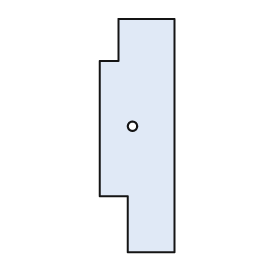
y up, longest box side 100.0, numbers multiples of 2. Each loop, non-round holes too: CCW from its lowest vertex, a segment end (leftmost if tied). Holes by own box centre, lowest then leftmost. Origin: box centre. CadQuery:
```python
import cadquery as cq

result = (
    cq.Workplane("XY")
    .moveTo(-4.0, -50.0)
    .lineTo(16.0, -50.0)
    .lineTo(16.0, 50.0)
    .lineTo(-8.0, 50.0)
    .lineTo(-8.0, 32.0)
    .lineTo(-16.0, 32.0)
    .lineTo(-16.0, -26.0)
    .lineTo(-4.0, -26.0)
    .close()
    .moveTo(-2.0, 4.0)
    .circle(2.0)
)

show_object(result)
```